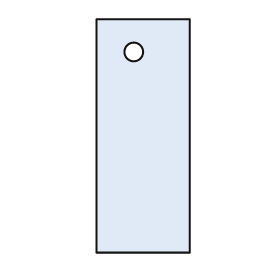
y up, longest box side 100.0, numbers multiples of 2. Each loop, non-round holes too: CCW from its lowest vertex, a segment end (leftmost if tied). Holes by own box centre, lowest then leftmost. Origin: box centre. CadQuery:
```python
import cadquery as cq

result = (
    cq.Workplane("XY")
    .moveTo(-20.0, -50.0)
    .lineTo(20.0, -50.0)
    .lineTo(20.0, 50.0)
    .lineTo(-20.0, 50.0)
    .close()
    .moveTo(-4.0, 36.0)
    .circle(4.0)
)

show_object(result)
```